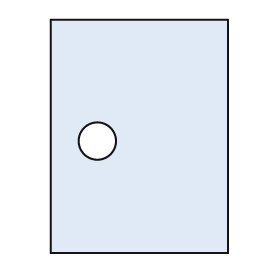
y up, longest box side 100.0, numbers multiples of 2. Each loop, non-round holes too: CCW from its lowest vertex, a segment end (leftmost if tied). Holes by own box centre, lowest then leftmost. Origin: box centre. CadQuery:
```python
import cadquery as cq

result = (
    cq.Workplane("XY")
    .moveTo(-38.0, -50.0)
    .lineTo(38.0, -50.0)
    .lineTo(38.0, 50.0)
    .lineTo(-38.0, 50.0)
    .close()
    .moveTo(-18.0, -2.0)
    .circle(8.0)
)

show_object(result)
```